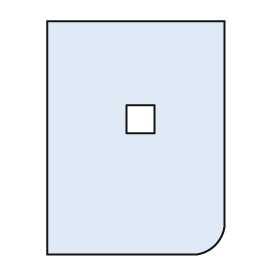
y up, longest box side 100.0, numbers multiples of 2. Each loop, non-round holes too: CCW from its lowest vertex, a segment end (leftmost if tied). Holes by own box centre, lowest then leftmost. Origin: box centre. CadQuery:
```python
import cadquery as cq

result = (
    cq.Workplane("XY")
    .moveTo(-38.0, -50.0)
    .lineTo(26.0, -50.0)
    .threePointArc((34.0, -46.0), (38.0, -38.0))
    .lineTo(38.0, 50.0)
    .lineTo(-38.0, 50.0)
    .close()
    .moveTo(-4.0, 2.0)
    .lineTo(8.0, 2.0)
    .lineTo(8.0, 14.0)
    .lineTo(-4.0, 14.0)
    .close()
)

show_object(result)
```